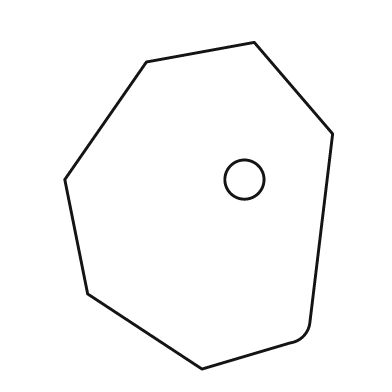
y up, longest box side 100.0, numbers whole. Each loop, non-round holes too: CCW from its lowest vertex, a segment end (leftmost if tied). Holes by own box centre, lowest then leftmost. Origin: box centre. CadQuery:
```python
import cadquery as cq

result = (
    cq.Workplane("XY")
    .moveTo(1.0, -50.0)
    .lineTo(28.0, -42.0)
    .threePointArc((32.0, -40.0), (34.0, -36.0))
    .lineTo(41.0, 22.0)
    .lineTo(17.0, 50.0)
    .lineTo(-16.0, 44.0)
    .lineTo(-41.0, 8.0)
    .lineTo(-34.0, -27.0)
    .close()
    .moveTo(14.0, 8.0)
    .circle(6.0)
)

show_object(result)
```